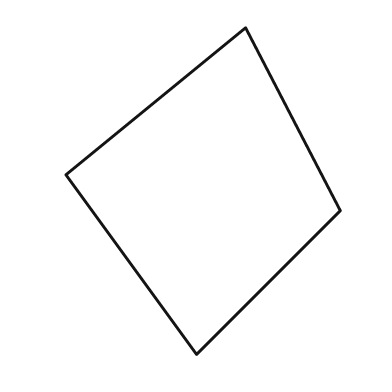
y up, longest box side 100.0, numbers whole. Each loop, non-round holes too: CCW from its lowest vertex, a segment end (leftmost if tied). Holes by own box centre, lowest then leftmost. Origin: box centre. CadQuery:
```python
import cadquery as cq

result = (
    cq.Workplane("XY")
    .moveTo(-2.0, -50.0)
    .lineTo(42.0, -6.0)
    .lineTo(13.0, 50.0)
    .lineTo(-42.0, 5.0)
    .close()
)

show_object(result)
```